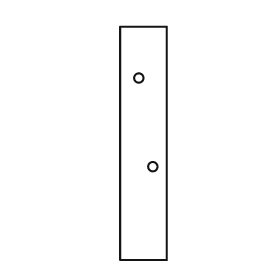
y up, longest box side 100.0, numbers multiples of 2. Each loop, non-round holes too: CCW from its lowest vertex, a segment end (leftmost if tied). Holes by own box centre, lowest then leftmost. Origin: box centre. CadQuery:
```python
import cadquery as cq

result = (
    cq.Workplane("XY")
    .moveTo(-10.0, -50.0)
    .lineTo(10.0, -50.0)
    .lineTo(10.0, 50.0)
    .lineTo(-10.0, 50.0)
    .close()
    .moveTo(4.0, -10.0)
    .circle(2.0)
    .moveTo(-2.0, 28.0)
    .circle(2.0)
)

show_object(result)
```